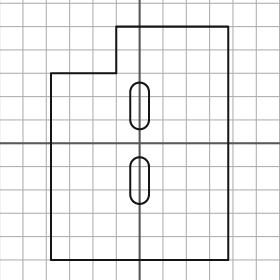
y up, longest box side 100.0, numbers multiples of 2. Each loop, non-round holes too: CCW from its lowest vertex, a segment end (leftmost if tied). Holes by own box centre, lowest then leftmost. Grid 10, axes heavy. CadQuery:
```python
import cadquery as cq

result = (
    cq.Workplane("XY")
    .moveTo(-38.0, -50.0)
    .lineTo(38.0, -50.0)
    .lineTo(38.0, 50.0)
    .lineTo(-10.0, 50.0)
    .lineTo(-10.0, 30.0)
    .lineTo(-38.0, 30.0)
    .close()
    .moveTo(-4.0, -22.0)
    .threePointArc((0.0, -26.0), (4.0, -22.0))
    .lineTo(4.0, -10.0)
    .threePointArc((0.0, -6.0), (-4.0, -10.0))
    .close()
    .moveTo(-4.0, 10.0)
    .threePointArc((0.0, 6.0), (4.0, 10.0))
    .lineTo(4.0, 22.0)
    .threePointArc((0.0, 26.0), (-4.0, 22.0))
    .close()
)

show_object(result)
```